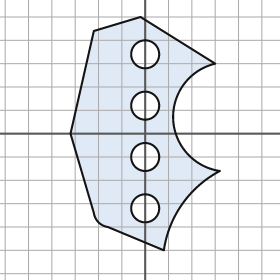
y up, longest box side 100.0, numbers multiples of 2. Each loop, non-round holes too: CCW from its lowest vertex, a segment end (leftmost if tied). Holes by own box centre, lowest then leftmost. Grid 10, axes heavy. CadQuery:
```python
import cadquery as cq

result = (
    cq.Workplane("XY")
    .moveTo(8.0, -50.0)
    .threePointArc((16.0, -30.0), (32.0, -16.0))
    .threePointArc((12.0, 6.0), (30.0, 30.0))
    .lineTo(-2.0, 50.0)
    .lineTo(-22.0, 44.0)
    .lineTo(-32.0, 0.0)
    .lineTo(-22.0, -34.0)
    .threePointArc((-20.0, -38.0), (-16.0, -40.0))
    .close()
    .moveTo(0.0, -32.0)
    .circle(6.0)
    .moveTo(0.0, -10.0)
    .circle(6.0)
    .moveTo(0.0, 12.0)
    .circle(6.0)
    .moveTo(0.0, 34.0)
    .circle(6.0)
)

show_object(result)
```